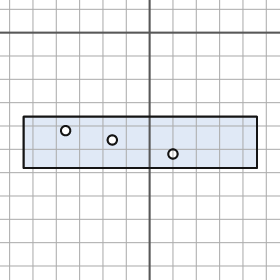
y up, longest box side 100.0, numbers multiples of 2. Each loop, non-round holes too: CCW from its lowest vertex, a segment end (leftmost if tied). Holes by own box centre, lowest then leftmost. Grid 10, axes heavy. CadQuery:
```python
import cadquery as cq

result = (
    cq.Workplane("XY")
    .moveTo(-54.0, -58.0)
    .lineTo(46.0, -58.0)
    .lineTo(46.0, -36.0)
    .lineTo(-54.0, -36.0)
    .close()
    .moveTo(10.0, -52.0)
    .circle(2.0)
    .moveTo(-16.0, -46.0)
    .circle(2.0)
    .moveTo(-36.0, -42.0)
    .circle(2.0)
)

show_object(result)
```